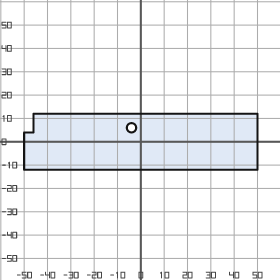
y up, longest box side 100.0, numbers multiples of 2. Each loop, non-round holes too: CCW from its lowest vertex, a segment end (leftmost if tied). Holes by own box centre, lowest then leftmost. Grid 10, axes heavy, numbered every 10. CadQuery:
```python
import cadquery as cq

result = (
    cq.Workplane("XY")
    .moveTo(-50.0, -12.0)
    .lineTo(50.0, -12.0)
    .lineTo(50.0, 12.0)
    .lineTo(-46.0, 12.0)
    .lineTo(-46.0, 4.0)
    .lineTo(-50.0, 4.0)
    .close()
    .moveTo(-4.0, 6.0)
    .circle(2.0)
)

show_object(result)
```